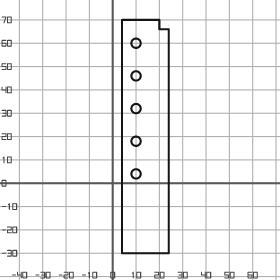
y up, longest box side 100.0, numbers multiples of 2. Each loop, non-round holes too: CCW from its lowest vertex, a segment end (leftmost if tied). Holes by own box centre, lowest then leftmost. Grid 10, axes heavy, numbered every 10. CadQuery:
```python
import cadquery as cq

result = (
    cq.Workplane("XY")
    .moveTo(4.0, -30.0)
    .lineTo(24.0, -30.0)
    .lineTo(24.0, 66.0)
    .lineTo(20.0, 66.0)
    .lineTo(20.0, 70.0)
    .lineTo(4.0, 70.0)
    .close()
    .moveTo(10.0, 4.0)
    .circle(2.0)
    .moveTo(10.0, 18.0)
    .circle(2.0)
    .moveTo(10.0, 32.0)
    .circle(2.0)
    .moveTo(10.0, 46.0)
    .circle(2.0)
    .moveTo(10.0, 60.0)
    .circle(2.0)
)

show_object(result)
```